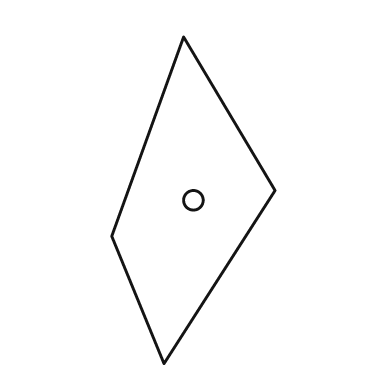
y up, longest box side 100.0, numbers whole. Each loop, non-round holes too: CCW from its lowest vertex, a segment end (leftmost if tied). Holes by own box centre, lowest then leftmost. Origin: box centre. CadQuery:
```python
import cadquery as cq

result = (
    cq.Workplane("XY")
    .moveTo(-9.0, -50.0)
    .lineTo(25.0, 3.0)
    .lineTo(-3.0, 50.0)
    .lineTo(-25.0, -11.0)
    .close()
    .moveTo(0.0, 0.0)
    .circle(3.0)
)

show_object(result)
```